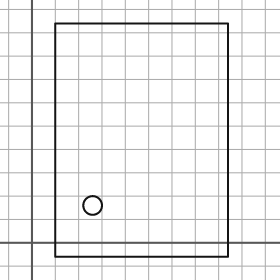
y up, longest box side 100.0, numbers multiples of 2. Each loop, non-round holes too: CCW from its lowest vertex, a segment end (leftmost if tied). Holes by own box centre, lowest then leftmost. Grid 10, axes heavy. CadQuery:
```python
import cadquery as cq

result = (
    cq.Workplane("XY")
    .moveTo(10.0, -6.0)
    .lineTo(84.0, -6.0)
    .lineTo(84.0, 94.0)
    .lineTo(10.0, 94.0)
    .close()
    .moveTo(26.0, 16.0)
    .circle(4.0)
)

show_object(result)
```